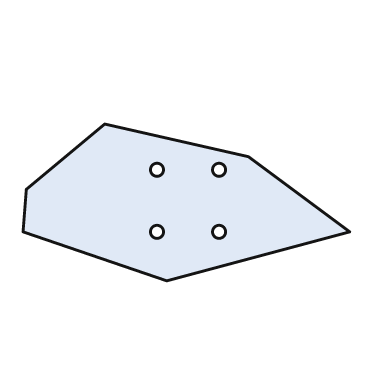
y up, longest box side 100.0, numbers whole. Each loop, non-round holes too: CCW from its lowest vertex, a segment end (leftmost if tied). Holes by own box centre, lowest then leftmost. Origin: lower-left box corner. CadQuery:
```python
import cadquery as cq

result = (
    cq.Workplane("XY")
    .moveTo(44.0, 0.0)
    .lineTo(100.0, 15.0)
    .lineTo(69.0, 38.0)
    .lineTo(25.0, 48.0)
    .lineTo(1.0, 28.0)
    .lineTo(0.0, 15.0)
    .close()
    .moveTo(41.0, 15.0)
    .circle(2.0)
    .moveTo(60.0, 15.0)
    .circle(2.0)
    .moveTo(41.0, 34.0)
    .circle(2.0)
    .moveTo(60.0, 34.0)
    .circle(2.0)
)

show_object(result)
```